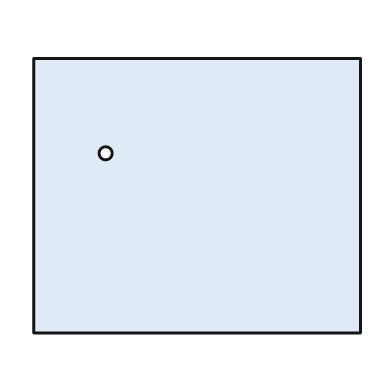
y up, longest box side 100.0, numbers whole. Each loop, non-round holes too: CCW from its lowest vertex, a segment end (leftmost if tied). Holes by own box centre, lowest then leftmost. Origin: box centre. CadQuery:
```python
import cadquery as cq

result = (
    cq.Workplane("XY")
    .moveTo(-50.0, -42.0)
    .lineTo(50.0, -42.0)
    .lineTo(50.0, 42.0)
    .lineTo(-50.0, 42.0)
    .close()
    .moveTo(-28.0, 13.0)
    .circle(2.0)
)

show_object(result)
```